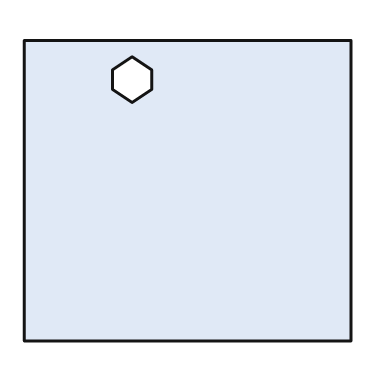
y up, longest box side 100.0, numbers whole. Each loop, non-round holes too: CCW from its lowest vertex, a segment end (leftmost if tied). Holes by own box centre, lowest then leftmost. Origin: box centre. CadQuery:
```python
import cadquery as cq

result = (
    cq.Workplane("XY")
    .moveTo(-50.0, -46.0)
    .lineTo(50.0, -46.0)
    .lineTo(50.0, 46.0)
    .lineTo(-50.0, 46.0)
    .close()
    .moveTo(-17.0, 27.0)
    .lineTo(-11.0, 31.0)
    .lineTo(-11.0, 37.0)
    .lineTo(-17.0, 41.0)
    .lineTo(-23.0, 37.0)
    .lineTo(-23.0, 31.0)
    .close()
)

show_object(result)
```